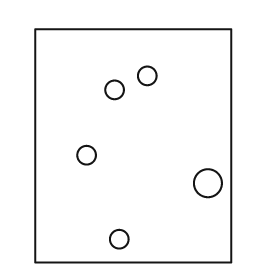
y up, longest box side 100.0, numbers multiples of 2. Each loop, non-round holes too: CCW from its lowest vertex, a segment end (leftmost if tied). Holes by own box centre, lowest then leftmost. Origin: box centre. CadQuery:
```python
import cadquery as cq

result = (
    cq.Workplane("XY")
    .moveTo(-42.0, -50.0)
    .lineTo(42.0, -50.0)
    .lineTo(42.0, 50.0)
    .lineTo(-42.0, 50.0)
    .close()
    .moveTo(-6.0, -40.0)
    .circle(4.0)
    .moveTo(32.0, -16.0)
    .circle(6.0)
    .moveTo(-20.0, -4.0)
    .circle(4.0)
    .moveTo(-8.0, 24.0)
    .circle(4.0)
    .moveTo(6.0, 30.0)
    .circle(4.0)
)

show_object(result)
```